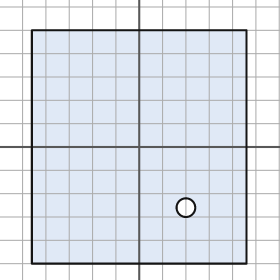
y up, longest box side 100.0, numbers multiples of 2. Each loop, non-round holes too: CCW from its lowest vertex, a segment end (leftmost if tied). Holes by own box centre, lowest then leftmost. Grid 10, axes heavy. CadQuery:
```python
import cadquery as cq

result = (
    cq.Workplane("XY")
    .moveTo(-46.0, -50.0)
    .lineTo(46.0, -50.0)
    .lineTo(46.0, 50.0)
    .lineTo(-46.0, 50.0)
    .close()
    .moveTo(20.0, -26.0)
    .circle(4.0)
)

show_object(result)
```